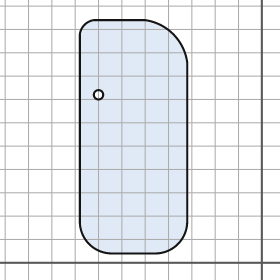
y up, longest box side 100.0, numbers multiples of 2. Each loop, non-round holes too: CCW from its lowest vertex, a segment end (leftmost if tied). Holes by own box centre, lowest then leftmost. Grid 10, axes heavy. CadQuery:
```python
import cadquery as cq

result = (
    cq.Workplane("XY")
    .moveTo(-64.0, 4.0)
    .lineTo(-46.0, 4.0)
    .threePointArc((-36.0, 8.0), (-32.0, 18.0))
    .lineTo(-32.0, 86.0)
    .threePointArc((-38.0, 98.0), (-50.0, 104.0))
    .lineTo(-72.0, 104.0)
    .threePointArc((-76.0, 102.0), (-78.0, 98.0))
    .lineTo(-78.0, 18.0)
    .threePointArc((-74.0, 8.0), (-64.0, 4.0))
    .close()
    .moveTo(-70.0, 72.0)
    .circle(2.0)
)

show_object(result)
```